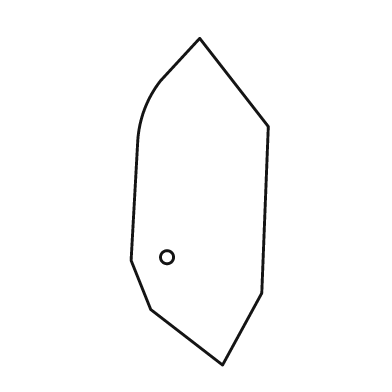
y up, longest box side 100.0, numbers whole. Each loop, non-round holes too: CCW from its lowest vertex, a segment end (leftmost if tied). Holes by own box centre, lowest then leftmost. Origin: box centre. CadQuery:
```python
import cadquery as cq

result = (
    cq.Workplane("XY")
    .moveTo(7.0, -50.0)
    .lineTo(19.0, -28.0)
    .lineTo(21.0, 23.0)
    .lineTo(0.0, 50.0)
    .lineTo(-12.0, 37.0)
    .threePointArc((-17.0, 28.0), (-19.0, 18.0))
    .lineTo(-21.0, -18.0)
    .lineTo(-15.0, -33.0)
    .close()
    .moveTo(-10.0, -17.0)
    .circle(2.0)
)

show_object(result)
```